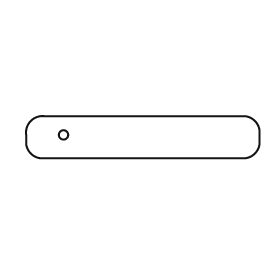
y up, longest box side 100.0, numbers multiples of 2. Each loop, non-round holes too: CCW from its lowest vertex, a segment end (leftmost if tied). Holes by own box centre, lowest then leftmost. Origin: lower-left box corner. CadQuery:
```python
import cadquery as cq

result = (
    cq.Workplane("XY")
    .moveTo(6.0, 0.0)
    .lineTo(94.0, 0.0)
    .threePointArc((98.0, 2.0), (100.0, 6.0))
    .lineTo(100.0, 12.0)
    .threePointArc((98.0, 16.0), (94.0, 18.0))
    .lineTo(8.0, 18.0)
    .threePointArc((2.0, 16.0), (0.0, 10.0))
    .lineTo(0.0, 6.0)
    .threePointArc((2.0, 2.0), (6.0, 0.0))
    .close()
    .moveTo(16.0, 10.0)
    .circle(2.0)
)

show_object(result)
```